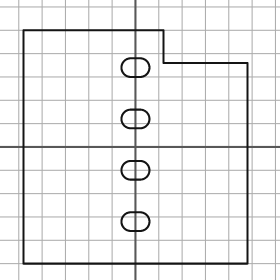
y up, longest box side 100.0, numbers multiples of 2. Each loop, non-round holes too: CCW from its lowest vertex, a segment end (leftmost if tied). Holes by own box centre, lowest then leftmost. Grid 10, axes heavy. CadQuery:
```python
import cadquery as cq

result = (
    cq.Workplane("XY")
    .moveTo(-48.0, -50.0)
    .lineTo(48.0, -50.0)
    .lineTo(48.0, 36.0)
    .lineTo(12.0, 36.0)
    .lineTo(12.0, 50.0)
    .lineTo(-48.0, 50.0)
    .close()
    .moveTo(-2.0, -36.0)
    .lineTo(2.0, -36.0)
    .threePointArc((6.0, -32.0), (2.0, -28.0))
    .lineTo(-2.0, -28.0)
    .threePointArc((-6.0, -32.0), (-2.0, -36.0))
    .close()
    .moveTo(-2.0, -14.0)
    .lineTo(2.0, -14.0)
    .threePointArc((6.0, -10.0), (2.0, -6.0))
    .lineTo(-2.0, -6.0)
    .threePointArc((-6.0, -10.0), (-2.0, -14.0))
    .close()
    .moveTo(-2.0, 8.0)
    .lineTo(2.0, 8.0)
    .threePointArc((6.0, 12.0), (2.0, 16.0))
    .lineTo(-2.0, 16.0)
    .threePointArc((-6.0, 12.0), (-2.0, 8.0))
    .close()
    .moveTo(-2.0, 30.0)
    .lineTo(2.0, 30.0)
    .threePointArc((6.0, 34.0), (2.0, 38.0))
    .lineTo(-2.0, 38.0)
    .threePointArc((-6.0, 34.0), (-2.0, 30.0))
    .close()
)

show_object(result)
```